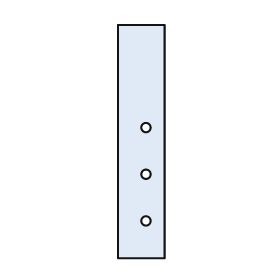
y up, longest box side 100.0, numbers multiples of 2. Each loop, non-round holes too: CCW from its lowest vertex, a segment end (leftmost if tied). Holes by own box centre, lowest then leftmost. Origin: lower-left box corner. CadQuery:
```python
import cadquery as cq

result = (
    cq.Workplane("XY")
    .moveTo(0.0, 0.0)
    .lineTo(20.0, 0.0)
    .lineTo(20.0, 100.0)
    .lineTo(0.0, 100.0)
    .close()
    .moveTo(12.0, 16.0)
    .circle(2.0)
    .moveTo(12.0, 36.0)
    .circle(2.0)
    .moveTo(12.0, 56.0)
    .circle(2.0)
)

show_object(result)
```